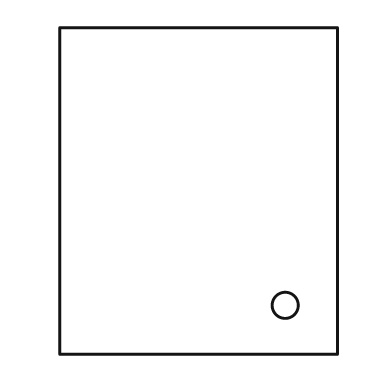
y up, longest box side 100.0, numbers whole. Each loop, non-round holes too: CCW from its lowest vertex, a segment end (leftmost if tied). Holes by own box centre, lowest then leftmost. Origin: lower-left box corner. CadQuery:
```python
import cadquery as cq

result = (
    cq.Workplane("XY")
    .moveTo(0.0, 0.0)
    .lineTo(85.0, 0.0)
    .lineTo(85.0, 100.0)
    .lineTo(0.0, 100.0)
    .close()
    .moveTo(69.0, 15.0)
    .circle(4.0)
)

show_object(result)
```